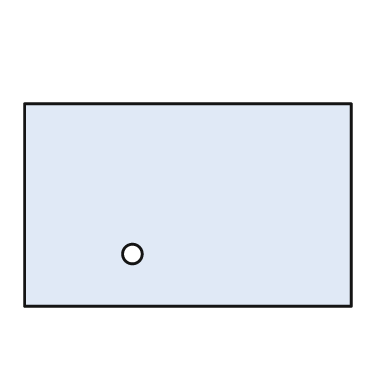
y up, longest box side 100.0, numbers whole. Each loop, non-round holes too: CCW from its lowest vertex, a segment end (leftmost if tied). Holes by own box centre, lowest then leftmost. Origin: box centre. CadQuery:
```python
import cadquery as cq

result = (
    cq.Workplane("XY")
    .moveTo(-50.0, -31.0)
    .lineTo(50.0, -31.0)
    .lineTo(50.0, 31.0)
    .lineTo(-50.0, 31.0)
    .close()
    .moveTo(-17.0, -15.0)
    .circle(3.0)
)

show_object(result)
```